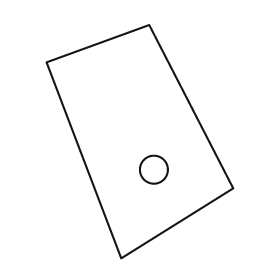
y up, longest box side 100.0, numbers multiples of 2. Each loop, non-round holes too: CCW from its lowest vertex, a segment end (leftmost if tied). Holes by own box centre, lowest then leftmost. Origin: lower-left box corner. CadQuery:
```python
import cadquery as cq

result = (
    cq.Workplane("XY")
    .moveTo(32.0, 0.0)
    .lineTo(80.0, 30.0)
    .lineTo(44.0, 100.0)
    .lineTo(0.0, 84.0)
    .close()
    .moveTo(46.0, 38.0)
    .circle(6.0)
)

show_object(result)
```